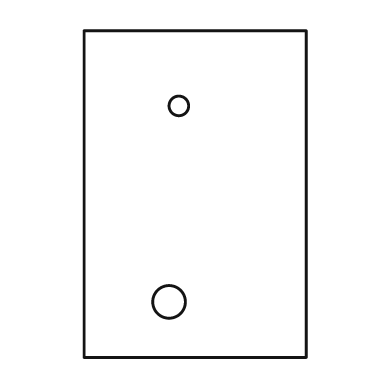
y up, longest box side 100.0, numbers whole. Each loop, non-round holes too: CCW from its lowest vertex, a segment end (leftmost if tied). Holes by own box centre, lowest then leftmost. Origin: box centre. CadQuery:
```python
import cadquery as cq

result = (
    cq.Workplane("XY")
    .moveTo(-34.0, -50.0)
    .lineTo(34.0, -50.0)
    .lineTo(34.0, 50.0)
    .lineTo(-34.0, 50.0)
    .close()
    .moveTo(-8.0, -33.0)
    .circle(5.0)
    .moveTo(-5.0, 27.0)
    .circle(3.0)
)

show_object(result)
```